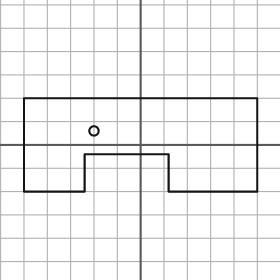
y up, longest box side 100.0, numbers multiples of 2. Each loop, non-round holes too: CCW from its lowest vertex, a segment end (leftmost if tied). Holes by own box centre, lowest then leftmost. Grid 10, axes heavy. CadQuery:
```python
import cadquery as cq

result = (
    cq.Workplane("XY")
    .moveTo(-50.0, -20.0)
    .lineTo(-24.0, -20.0)
    .lineTo(-24.0, -4.0)
    .lineTo(12.0, -4.0)
    .lineTo(12.0, -20.0)
    .lineTo(50.0, -20.0)
    .lineTo(50.0, 20.0)
    .lineTo(-50.0, 20.0)
    .close()
    .moveTo(-20.0, 6.0)
    .circle(2.0)
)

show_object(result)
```